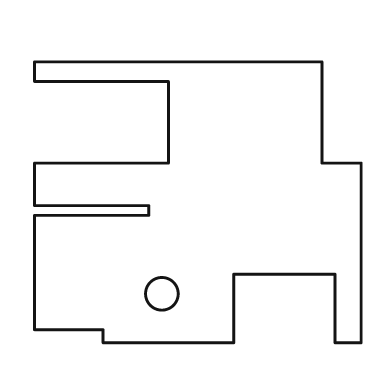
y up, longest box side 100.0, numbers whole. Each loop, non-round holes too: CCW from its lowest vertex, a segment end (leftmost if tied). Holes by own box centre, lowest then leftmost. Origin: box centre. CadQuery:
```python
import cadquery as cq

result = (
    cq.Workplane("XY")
    .moveTo(-29.0, -43.0)
    .lineTo(11.0, -43.0)
    .lineTo(11.0, -22.0)
    .lineTo(42.0, -22.0)
    .lineTo(42.0, -43.0)
    .lineTo(50.0, -43.0)
    .lineTo(50.0, 12.0)
    .lineTo(38.0, 12.0)
    .lineTo(38.0, 43.0)
    .lineTo(-50.0, 43.0)
    .lineTo(-50.0, 37.0)
    .lineTo(-9.0, 37.0)
    .lineTo(-9.0, 12.0)
    .lineTo(-50.0, 12.0)
    .lineTo(-50.0, -1.0)
    .lineTo(-15.0, -1.0)
    .lineTo(-15.0, -4.0)
    .lineTo(-50.0, -4.0)
    .lineTo(-50.0, -39.0)
    .lineTo(-29.0, -39.0)
    .close()
    .moveTo(-11.0, -28.0)
    .circle(5.0)
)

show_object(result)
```